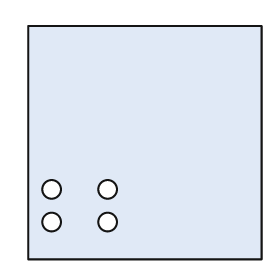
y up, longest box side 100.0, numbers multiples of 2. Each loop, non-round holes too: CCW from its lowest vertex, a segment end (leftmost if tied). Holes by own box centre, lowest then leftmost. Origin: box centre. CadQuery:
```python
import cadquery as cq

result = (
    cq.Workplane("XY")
    .moveTo(-50.0, -50.0)
    .lineTo(50.0, -50.0)
    .lineTo(50.0, 50.0)
    .lineTo(-50.0, 50.0)
    .close()
    .moveTo(-40.0, -34.0)
    .circle(4.0)
    .moveTo(-16.0, -34.0)
    .circle(4.0)
    .moveTo(-40.0, -20.0)
    .circle(4.0)
    .moveTo(-16.0, -20.0)
    .circle(4.0)
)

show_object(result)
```